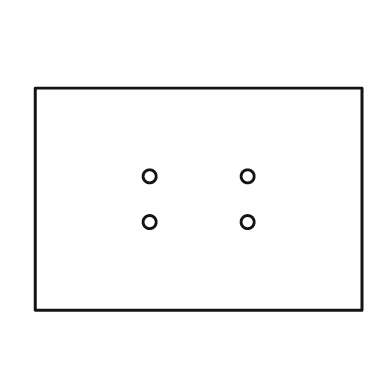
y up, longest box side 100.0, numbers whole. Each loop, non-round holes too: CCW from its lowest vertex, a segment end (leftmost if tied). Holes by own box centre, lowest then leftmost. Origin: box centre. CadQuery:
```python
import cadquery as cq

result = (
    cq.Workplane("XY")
    .moveTo(-50.0, -34.0)
    .lineTo(50.0, -34.0)
    .lineTo(50.0, 34.0)
    .lineTo(-50.0, 34.0)
    .close()
    .moveTo(-15.0, -7.0)
    .circle(2.0)
    .moveTo(15.0, -7.0)
    .circle(2.0)
    .moveTo(-15.0, 7.0)
    .circle(2.0)
    .moveTo(15.0, 7.0)
    .circle(2.0)
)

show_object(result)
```